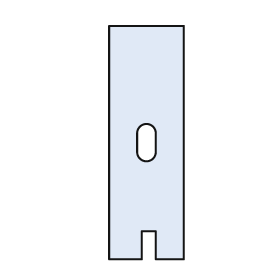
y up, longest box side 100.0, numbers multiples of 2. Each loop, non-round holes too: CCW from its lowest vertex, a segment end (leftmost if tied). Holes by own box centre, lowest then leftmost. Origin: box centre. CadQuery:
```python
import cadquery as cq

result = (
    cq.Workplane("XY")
    .moveTo(-16.0, -50.0)
    .lineTo(-2.0, -50.0)
    .lineTo(-2.0, -38.0)
    .lineTo(4.0, -38.0)
    .lineTo(4.0, -50.0)
    .lineTo(16.0, -50.0)
    .lineTo(16.0, 50.0)
    .lineTo(-16.0, 50.0)
    .close()
    .moveTo(-4.0, -4.0)
    .threePointArc((0.0, -8.0), (4.0, -4.0))
    .lineTo(4.0, 4.0)
    .threePointArc((0.0, 8.0), (-4.0, 4.0))
    .close()
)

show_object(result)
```